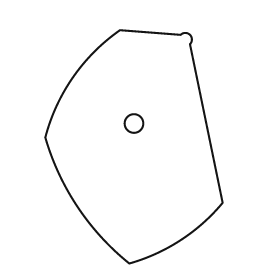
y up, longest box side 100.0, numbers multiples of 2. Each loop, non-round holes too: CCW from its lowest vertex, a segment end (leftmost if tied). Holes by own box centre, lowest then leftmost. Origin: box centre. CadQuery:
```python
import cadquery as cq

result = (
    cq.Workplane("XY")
    .moveTo(-2.0, -50.0)
    .threePointArc((20.0, -40.0), (38.0, -24.0))
    .lineTo(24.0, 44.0)
    .threePointArc((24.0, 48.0), (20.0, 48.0))
    .lineTo(-6.0, 50.0)
    .threePointArc((-26.0, 30.0), (-38.0, 4.0))
    .threePointArc((-24.0, -26.0), (-2.0, -50.0))
    .close()
    .moveTo(0.0, 10.0)
    .circle(4.0)
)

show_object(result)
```